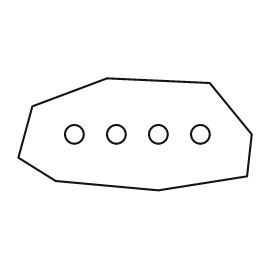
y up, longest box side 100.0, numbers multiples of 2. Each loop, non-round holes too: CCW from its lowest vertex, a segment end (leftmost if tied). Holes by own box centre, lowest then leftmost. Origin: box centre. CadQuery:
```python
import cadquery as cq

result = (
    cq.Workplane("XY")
    .moveTo(10.0, -24.0)
    .lineTo(48.0, -18.0)
    .lineTo(50.0, 0.0)
    .lineTo(32.0, 22.0)
    .lineTo(-12.0, 24.0)
    .lineTo(-44.0, 12.0)
    .lineTo(-50.0, -10.0)
    .lineTo(-34.0, -20.0)
    .close()
    .moveTo(-26.0, 0.0)
    .circle(4.0)
    .moveTo(-8.0, 0.0)
    .circle(4.0)
    .moveTo(10.0, 0.0)
    .circle(4.0)
    .moveTo(28.0, 0.0)
    .circle(4.0)
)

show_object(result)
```